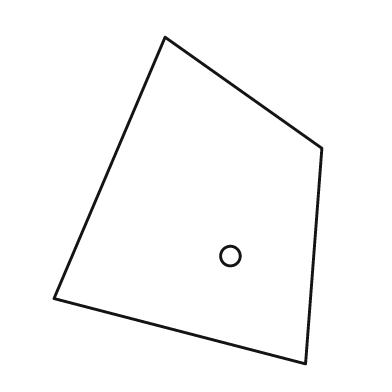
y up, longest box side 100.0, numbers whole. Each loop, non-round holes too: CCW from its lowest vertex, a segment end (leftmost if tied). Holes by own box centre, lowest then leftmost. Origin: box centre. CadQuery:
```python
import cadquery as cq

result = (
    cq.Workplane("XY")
    .moveTo(36.0, -50.0)
    .lineTo(41.0, 16.0)
    .lineTo(-7.0, 50.0)
    .lineTo(-41.0, -30.0)
    .close()
    .moveTo(13.0, -17.0)
    .circle(3.0)
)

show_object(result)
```